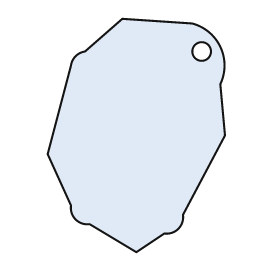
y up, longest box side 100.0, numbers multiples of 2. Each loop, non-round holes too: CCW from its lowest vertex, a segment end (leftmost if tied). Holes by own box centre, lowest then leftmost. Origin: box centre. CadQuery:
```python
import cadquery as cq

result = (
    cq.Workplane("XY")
    .moveTo(0.0, -50.0)
    .lineTo(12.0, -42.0)
    .threePointArc((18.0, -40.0), (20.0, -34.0))
    .lineTo(38.0, 0.0)
    .lineTo(36.0, 22.0)
    .threePointArc((36.0, 38.0), (24.0, 48.0))
    .lineTo(-6.0, 50.0)
    .lineTo(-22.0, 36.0)
    .threePointArc((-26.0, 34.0), (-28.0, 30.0))
    .lineTo(-38.0, -8.0)
    .lineTo(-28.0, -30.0)
    .threePointArc((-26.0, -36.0), (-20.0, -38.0))
    .close()
    .moveTo(28.0, 36.0)
    .circle(4.0)
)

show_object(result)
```